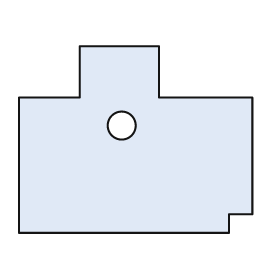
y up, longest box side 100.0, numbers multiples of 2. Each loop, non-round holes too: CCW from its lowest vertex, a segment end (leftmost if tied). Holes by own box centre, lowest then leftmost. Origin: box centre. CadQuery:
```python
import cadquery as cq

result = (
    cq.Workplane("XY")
    .moveTo(-50.0, -40.0)
    .lineTo(40.0, -40.0)
    .lineTo(40.0, -32.0)
    .lineTo(50.0, -32.0)
    .lineTo(50.0, 18.0)
    .lineTo(10.0, 18.0)
    .lineTo(10.0, 40.0)
    .lineTo(-24.0, 40.0)
    .lineTo(-24.0, 18.0)
    .lineTo(-50.0, 18.0)
    .close()
    .moveTo(-6.0, 6.0)
    .circle(6.0)
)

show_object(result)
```